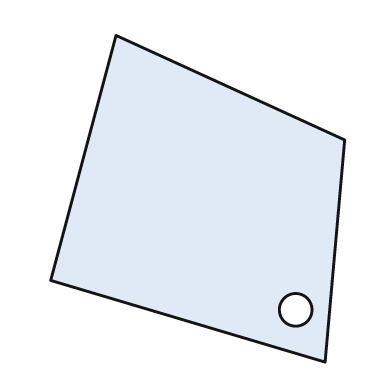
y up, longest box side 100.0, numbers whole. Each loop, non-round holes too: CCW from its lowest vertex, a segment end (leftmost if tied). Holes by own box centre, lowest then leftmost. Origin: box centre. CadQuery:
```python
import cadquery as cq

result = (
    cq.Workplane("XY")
    .moveTo(39.0, -50.0)
    .lineTo(45.0, 18.0)
    .lineTo(-25.0, 50.0)
    .lineTo(-45.0, -25.0)
    .close()
    .moveTo(30.0, -34.0)
    .circle(5.0)
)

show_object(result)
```